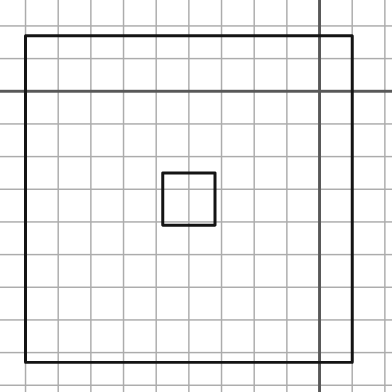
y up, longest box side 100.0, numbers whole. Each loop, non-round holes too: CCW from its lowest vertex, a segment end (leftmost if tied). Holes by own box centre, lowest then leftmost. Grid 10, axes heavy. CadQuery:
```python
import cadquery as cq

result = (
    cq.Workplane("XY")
    .moveTo(-90.0, -83.0)
    .lineTo(10.0, -83.0)
    .lineTo(10.0, 17.0)
    .lineTo(-90.0, 17.0)
    .close()
    .moveTo(-48.0, -41.0)
    .lineTo(-32.0, -41.0)
    .lineTo(-32.0, -25.0)
    .lineTo(-48.0, -25.0)
    .close()
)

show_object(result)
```